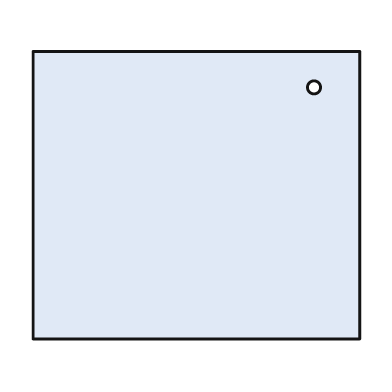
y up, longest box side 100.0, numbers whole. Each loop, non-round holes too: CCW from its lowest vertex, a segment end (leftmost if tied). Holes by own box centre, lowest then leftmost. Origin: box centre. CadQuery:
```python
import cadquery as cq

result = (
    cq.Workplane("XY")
    .moveTo(-50.0, -44.0)
    .lineTo(50.0, -44.0)
    .lineTo(50.0, 44.0)
    .lineTo(-50.0, 44.0)
    .close()
    .moveTo(36.0, 33.0)
    .circle(2.0)
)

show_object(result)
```